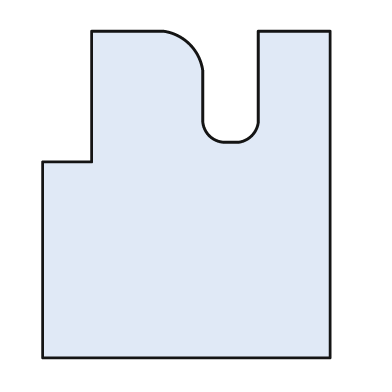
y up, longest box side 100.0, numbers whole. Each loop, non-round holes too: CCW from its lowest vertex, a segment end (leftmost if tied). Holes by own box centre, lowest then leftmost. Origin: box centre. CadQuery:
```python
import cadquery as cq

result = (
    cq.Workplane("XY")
    .moveTo(-44.0, -50.0)
    .lineTo(44.0, -50.0)
    .lineTo(44.0, 50.0)
    .lineTo(22.0, 50.0)
    .lineTo(22.0, 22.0)
    .threePointArc((20.0, 18.0), (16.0, 16.0))
    .lineTo(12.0, 16.0)
    .threePointArc((7.0, 18.0), (5.0, 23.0))
    .lineTo(5.0, 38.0)
    .threePointArc((1.0, 46.0), (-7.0, 50.0))
    .lineTo(-29.0, 50.0)
    .lineTo(-29.0, 10.0)
    .lineTo(-44.0, 10.0)
    .close()
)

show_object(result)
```